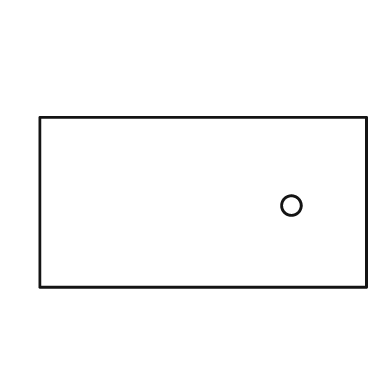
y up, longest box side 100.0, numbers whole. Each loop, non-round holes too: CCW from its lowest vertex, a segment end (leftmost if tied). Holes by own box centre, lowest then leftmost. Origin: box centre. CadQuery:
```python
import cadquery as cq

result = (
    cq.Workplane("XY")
    .moveTo(-50.0, -26.0)
    .lineTo(50.0, -26.0)
    .lineTo(50.0, 26.0)
    .lineTo(-50.0, 26.0)
    .close()
    .moveTo(27.0, -1.0)
    .circle(3.0)
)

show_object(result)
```